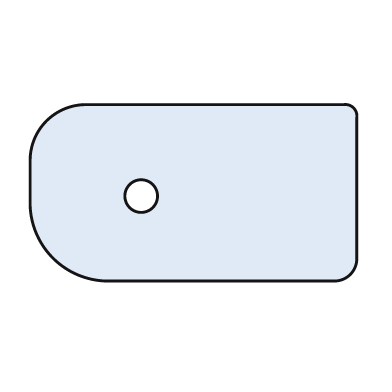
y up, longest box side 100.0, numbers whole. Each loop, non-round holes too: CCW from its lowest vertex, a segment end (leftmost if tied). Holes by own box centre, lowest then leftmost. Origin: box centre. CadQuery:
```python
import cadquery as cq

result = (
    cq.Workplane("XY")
    .moveTo(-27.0, -27.0)
    .lineTo(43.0, -27.0)
    .threePointArc((48.0, -25.0), (50.0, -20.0))
    .lineTo(50.0, 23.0)
    .threePointArc((49.0, 26.0), (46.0, 27.0))
    .lineTo(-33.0, 27.0)
    .threePointArc((-45.0, 22.0), (-50.0, 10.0))
    .lineTo(-50.0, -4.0)
    .threePointArc((-43.0, -20.0), (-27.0, -27.0))
    .close()
    .moveTo(-16.0, -1.0)
    .circle(5.0)
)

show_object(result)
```